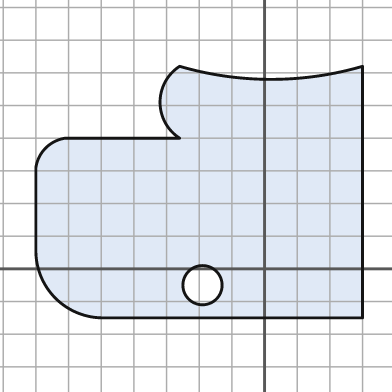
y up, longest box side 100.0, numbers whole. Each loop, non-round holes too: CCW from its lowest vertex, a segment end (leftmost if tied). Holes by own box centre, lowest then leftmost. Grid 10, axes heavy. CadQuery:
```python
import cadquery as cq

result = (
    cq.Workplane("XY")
    .moveTo(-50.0, -15.0)
    .lineTo(30.0, -15.0)
    .lineTo(30.0, 62.0)
    .threePointArc((2.0, 58.0), (-26.0, 62.0))
    .threePointArc((-32.0, 51.0), (-26.0, 40.0))
    .lineTo(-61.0, 40.0)
    .threePointArc((-67.0, 37.0), (-70.0, 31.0))
    .lineTo(-70.0, 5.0)
    .threePointArc((-64.0, -9.0), (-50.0, -15.0))
    .close()
    .moveTo(-19.0, -5.0)
    .circle(6.0)
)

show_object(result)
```